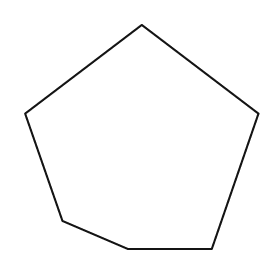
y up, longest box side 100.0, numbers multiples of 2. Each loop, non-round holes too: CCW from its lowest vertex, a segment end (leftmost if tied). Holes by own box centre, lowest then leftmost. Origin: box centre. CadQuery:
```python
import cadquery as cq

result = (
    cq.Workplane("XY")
    .moveTo(-6.0, -48.0)
    .lineTo(30.0, -48.0)
    .lineTo(50.0, 10.0)
    .lineTo(0.0, 48.0)
    .lineTo(-50.0, 10.0)
    .lineTo(-34.0, -36.0)
    .close()
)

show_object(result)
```